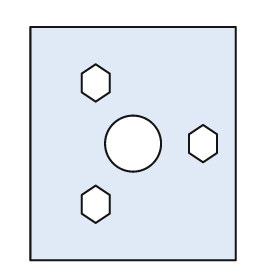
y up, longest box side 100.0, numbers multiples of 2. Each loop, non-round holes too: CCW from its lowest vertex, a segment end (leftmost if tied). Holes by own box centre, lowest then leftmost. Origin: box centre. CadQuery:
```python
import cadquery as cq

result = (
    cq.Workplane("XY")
    .moveTo(-44.0, -50.0)
    .lineTo(44.0, -50.0)
    .lineTo(44.0, 50.0)
    .lineTo(-44.0, 50.0)
    .close()
    .moveTo(-16.0, -34.0)
    .lineTo(-10.0, -30.0)
    .lineTo(-10.0, -22.0)
    .lineTo(-16.0, -18.0)
    .lineTo(-22.0, -22.0)
    .lineTo(-22.0, -30.0)
    .close()
    .moveTo(0.0, 0.0)
    .circle(12.0)
    .moveTo(30.0, -8.0)
    .lineTo(36.0, -4.0)
    .lineTo(36.0, 4.0)
    .lineTo(30.0, 8.0)
    .lineTo(24.0, 4.0)
    .lineTo(24.0, -4.0)
    .close()
    .moveTo(-16.0, 18.0)
    .lineTo(-10.0, 22.0)
    .lineTo(-10.0, 30.0)
    .lineTo(-16.0, 34.0)
    .lineTo(-22.0, 30.0)
    .lineTo(-22.0, 22.0)
    .close()
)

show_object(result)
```